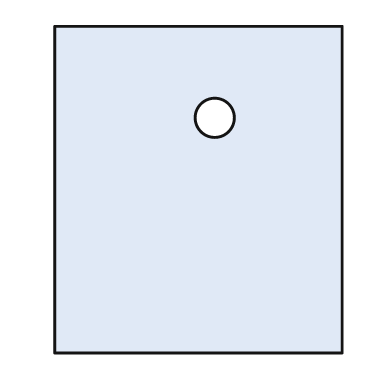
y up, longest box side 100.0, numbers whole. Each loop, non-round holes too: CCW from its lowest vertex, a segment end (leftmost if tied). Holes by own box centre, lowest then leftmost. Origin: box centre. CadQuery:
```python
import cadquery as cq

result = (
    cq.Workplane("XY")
    .moveTo(-44.0, -50.0)
    .lineTo(44.0, -50.0)
    .lineTo(44.0, 50.0)
    .lineTo(-44.0, 50.0)
    .close()
    .moveTo(5.0, 22.0)
    .circle(6.0)
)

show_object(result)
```